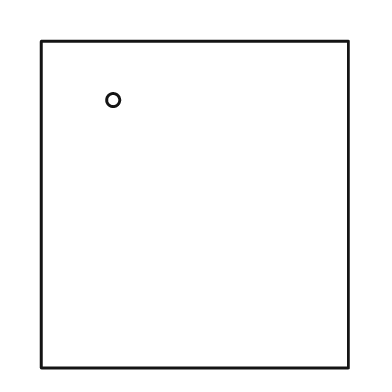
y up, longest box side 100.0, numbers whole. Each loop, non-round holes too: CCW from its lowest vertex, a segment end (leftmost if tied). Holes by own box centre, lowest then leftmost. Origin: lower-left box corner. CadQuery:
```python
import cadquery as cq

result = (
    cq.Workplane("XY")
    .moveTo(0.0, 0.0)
    .lineTo(94.0, 0.0)
    .lineTo(94.0, 100.0)
    .lineTo(0.0, 100.0)
    .close()
    .moveTo(22.0, 82.0)
    .circle(2.0)
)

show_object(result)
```